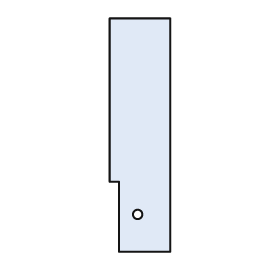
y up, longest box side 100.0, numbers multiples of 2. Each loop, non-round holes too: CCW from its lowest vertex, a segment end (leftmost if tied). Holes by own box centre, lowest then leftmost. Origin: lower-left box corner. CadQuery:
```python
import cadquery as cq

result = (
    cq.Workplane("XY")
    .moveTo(4.0, 0.0)
    .lineTo(26.0, 0.0)
    .lineTo(26.0, 100.0)
    .lineTo(0.0, 100.0)
    .lineTo(0.0, 30.0)
    .lineTo(4.0, 30.0)
    .close()
    .moveTo(12.0, 16.0)
    .circle(2.0)
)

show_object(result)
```